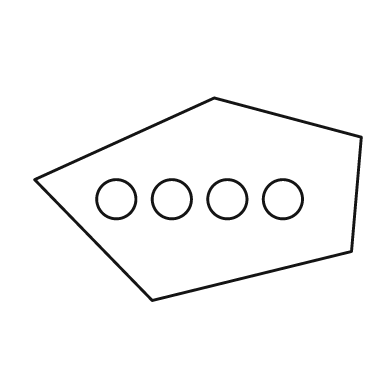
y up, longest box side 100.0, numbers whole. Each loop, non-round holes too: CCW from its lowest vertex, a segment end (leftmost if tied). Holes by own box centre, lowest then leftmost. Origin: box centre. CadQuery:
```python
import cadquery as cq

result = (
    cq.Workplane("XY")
    .moveTo(-14.0, -31.0)
    .lineTo(47.0, -16.0)
    .lineTo(50.0, 19.0)
    .lineTo(5.0, 31.0)
    .lineTo(-50.0, 6.0)
    .close()
    .moveTo(-25.0, 0.0)
    .circle(6.0)
    .moveTo(-8.0, 0.0)
    .circle(6.0)
    .moveTo(9.0, 0.0)
    .circle(6.0)
    .moveTo(26.0, 0.0)
    .circle(6.0)
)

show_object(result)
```